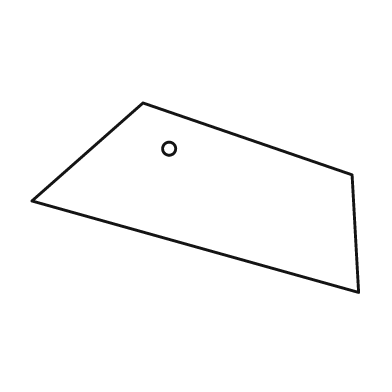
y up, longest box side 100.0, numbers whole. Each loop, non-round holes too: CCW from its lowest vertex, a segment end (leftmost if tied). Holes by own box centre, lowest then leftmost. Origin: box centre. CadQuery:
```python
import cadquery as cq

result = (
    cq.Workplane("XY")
    .moveTo(50.0, -29.0)
    .lineTo(48.0, 7.0)
    .lineTo(-16.0, 29.0)
    .lineTo(-50.0, -1.0)
    .close()
    .moveTo(-8.0, 15.0)
    .circle(2.0)
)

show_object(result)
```